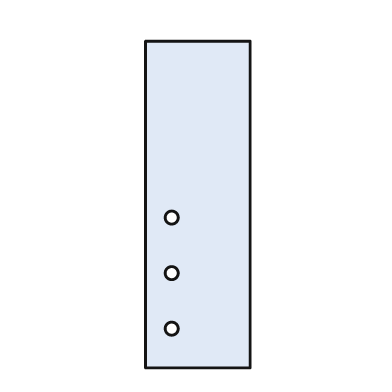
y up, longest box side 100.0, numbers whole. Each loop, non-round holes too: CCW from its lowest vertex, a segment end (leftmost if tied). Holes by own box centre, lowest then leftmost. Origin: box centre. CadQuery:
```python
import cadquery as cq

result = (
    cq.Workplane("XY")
    .moveTo(-16.0, -50.0)
    .lineTo(16.0, -50.0)
    .lineTo(16.0, 50.0)
    .lineTo(-16.0, 50.0)
    .close()
    .moveTo(-8.0, -38.0)
    .circle(2.0)
    .moveTo(-8.0, -21.0)
    .circle(2.0)
    .moveTo(-8.0, -4.0)
    .circle(2.0)
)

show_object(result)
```